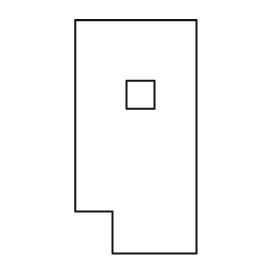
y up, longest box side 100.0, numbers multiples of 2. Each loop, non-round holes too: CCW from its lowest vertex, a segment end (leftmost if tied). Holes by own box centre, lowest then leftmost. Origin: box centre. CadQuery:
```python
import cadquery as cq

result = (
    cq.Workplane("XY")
    .moveTo(-10.0, -50.0)
    .lineTo(26.0, -50.0)
    .lineTo(26.0, 50.0)
    .lineTo(-26.0, 50.0)
    .lineTo(-26.0, -32.0)
    .lineTo(-10.0, -32.0)
    .close()
    .moveTo(-4.0, 12.0)
    .lineTo(8.0, 12.0)
    .lineTo(8.0, 24.0)
    .lineTo(-4.0, 24.0)
    .close()
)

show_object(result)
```